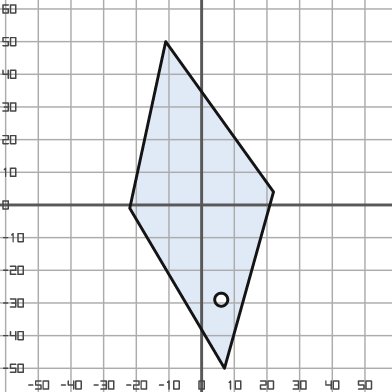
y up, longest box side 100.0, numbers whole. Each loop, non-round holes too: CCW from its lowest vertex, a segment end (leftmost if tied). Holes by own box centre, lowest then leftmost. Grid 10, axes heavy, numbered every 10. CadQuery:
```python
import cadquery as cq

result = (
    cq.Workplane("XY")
    .moveTo(7.0, -50.0)
    .lineTo(22.0, 4.0)
    .lineTo(-11.0, 50.0)
    .lineTo(-22.0, -1.0)
    .close()
    .moveTo(6.0, -29.0)
    .circle(2.0)
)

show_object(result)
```